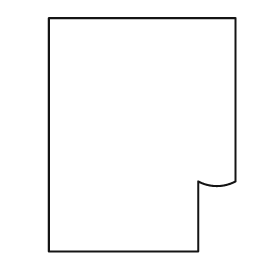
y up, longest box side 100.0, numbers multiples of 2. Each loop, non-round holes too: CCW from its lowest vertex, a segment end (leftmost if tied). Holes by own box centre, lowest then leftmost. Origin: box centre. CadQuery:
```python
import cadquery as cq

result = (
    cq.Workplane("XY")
    .moveTo(-40.0, -50.0)
    .lineTo(24.0, -50.0)
    .lineTo(24.0, -20.0)
    .threePointArc((32.0, -22.0), (40.0, -20.0))
    .lineTo(40.0, 50.0)
    .lineTo(-40.0, 50.0)
    .close()
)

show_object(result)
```